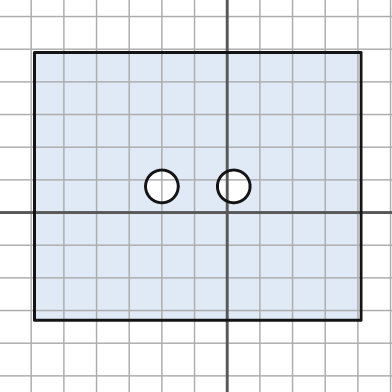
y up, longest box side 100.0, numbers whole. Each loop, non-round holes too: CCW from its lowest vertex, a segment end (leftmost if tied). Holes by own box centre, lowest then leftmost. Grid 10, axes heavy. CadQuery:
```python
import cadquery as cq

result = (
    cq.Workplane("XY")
    .moveTo(-59.0, -33.0)
    .lineTo(41.0, -33.0)
    .lineTo(41.0, 49.0)
    .lineTo(-59.0, 49.0)
    .close()
    .moveTo(-20.0, 8.0)
    .circle(5.0)
    .moveTo(2.0, 8.0)
    .circle(5.0)
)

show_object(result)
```